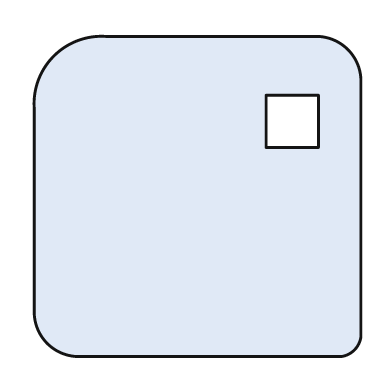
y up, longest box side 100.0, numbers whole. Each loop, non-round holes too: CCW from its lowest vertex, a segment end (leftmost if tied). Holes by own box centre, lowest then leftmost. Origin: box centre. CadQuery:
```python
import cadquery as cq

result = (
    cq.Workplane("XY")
    .moveTo(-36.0, -49.0)
    .lineTo(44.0, -49.0)
    .threePointArc((48.0, -47.0), (50.0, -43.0))
    .lineTo(50.0, 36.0)
    .threePointArc((46.0, 45.0), (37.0, 49.0))
    .lineTo(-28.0, 49.0)
    .threePointArc((-44.0, 43.0), (-50.0, 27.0))
    .lineTo(-50.0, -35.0)
    .threePointArc((-46.0, -45.0), (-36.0, -49.0))
    .close()
    .moveTo(21.0, 15.0)
    .lineTo(37.0, 15.0)
    .lineTo(37.0, 31.0)
    .lineTo(21.0, 31.0)
    .close()
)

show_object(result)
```